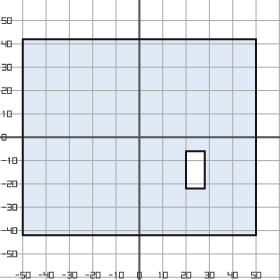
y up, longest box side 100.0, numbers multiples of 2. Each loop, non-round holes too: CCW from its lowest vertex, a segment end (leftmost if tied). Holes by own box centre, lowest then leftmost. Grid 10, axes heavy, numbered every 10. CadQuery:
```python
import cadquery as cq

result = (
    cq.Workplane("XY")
    .moveTo(-50.0, -42.0)
    .lineTo(50.0, -42.0)
    .lineTo(50.0, 42.0)
    .lineTo(-50.0, 42.0)
    .close()
    .moveTo(20.0, -22.0)
    .lineTo(28.0, -22.0)
    .lineTo(28.0, -6.0)
    .lineTo(20.0, -6.0)
    .close()
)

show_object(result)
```